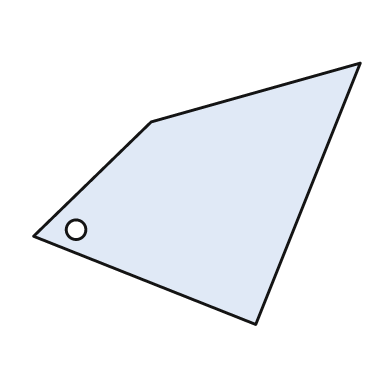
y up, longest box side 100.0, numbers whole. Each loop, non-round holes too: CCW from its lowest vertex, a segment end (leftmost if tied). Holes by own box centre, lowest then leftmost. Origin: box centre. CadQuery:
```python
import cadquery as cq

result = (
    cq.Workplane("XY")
    .moveTo(18.0, -40.0)
    .lineTo(50.0, 40.0)
    .lineTo(-14.0, 22.0)
    .lineTo(-50.0, -13.0)
    .close()
    .moveTo(-37.0, -11.0)
    .circle(3.0)
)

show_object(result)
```